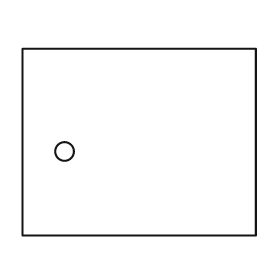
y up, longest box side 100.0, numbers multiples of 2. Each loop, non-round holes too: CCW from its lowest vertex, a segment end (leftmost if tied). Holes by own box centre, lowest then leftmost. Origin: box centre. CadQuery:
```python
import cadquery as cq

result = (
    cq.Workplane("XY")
    .moveTo(-50.0, -40.0)
    .lineTo(50.0, -40.0)
    .lineTo(50.0, 40.0)
    .lineTo(-50.0, 40.0)
    .close()
    .moveTo(-32.0, -4.0)
    .circle(4.0)
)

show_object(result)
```